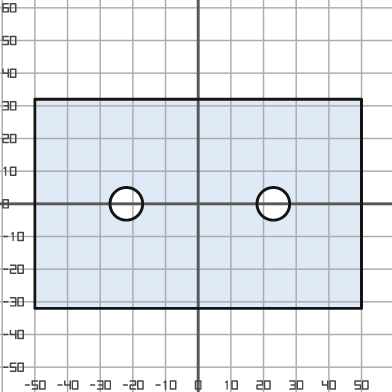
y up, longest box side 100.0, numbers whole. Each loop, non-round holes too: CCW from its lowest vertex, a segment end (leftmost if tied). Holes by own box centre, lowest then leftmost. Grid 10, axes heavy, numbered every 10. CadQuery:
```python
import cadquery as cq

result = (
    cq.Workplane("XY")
    .moveTo(-50.0, -32.0)
    .lineTo(50.0, -32.0)
    .lineTo(50.0, 32.0)
    .lineTo(-50.0, 32.0)
    .close()
    .moveTo(-22.0, 0.0)
    .circle(5.0)
    .moveTo(23.0, 0.0)
    .circle(5.0)
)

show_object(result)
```